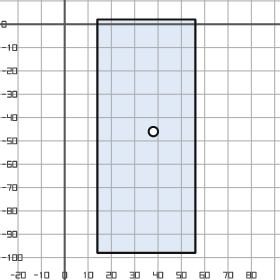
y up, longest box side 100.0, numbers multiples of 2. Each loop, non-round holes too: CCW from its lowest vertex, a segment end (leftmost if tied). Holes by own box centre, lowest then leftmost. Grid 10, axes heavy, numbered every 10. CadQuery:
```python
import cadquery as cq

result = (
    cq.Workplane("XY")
    .moveTo(14.0, -98.0)
    .lineTo(56.0, -98.0)
    .lineTo(56.0, 2.0)
    .lineTo(14.0, 2.0)
    .close()
    .moveTo(38.0, -46.0)
    .circle(2.0)
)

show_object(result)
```